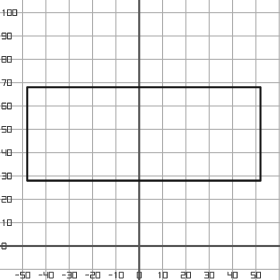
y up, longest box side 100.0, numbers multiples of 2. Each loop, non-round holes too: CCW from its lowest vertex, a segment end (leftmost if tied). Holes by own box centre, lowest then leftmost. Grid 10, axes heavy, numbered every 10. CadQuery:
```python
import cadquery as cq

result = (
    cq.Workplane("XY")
    .moveTo(-48.0, 28.0)
    .lineTo(52.0, 28.0)
    .lineTo(52.0, 68.0)
    .lineTo(-48.0, 68.0)
    .close()
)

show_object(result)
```